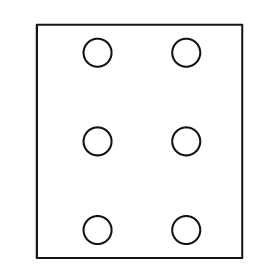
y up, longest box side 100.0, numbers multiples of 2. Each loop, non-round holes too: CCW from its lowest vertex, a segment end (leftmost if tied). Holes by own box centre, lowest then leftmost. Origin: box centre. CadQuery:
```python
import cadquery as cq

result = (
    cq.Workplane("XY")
    .moveTo(-44.0, -50.0)
    .lineTo(44.0, -50.0)
    .lineTo(44.0, 50.0)
    .lineTo(-44.0, 50.0)
    .close()
    .moveTo(-18.0, -38.0)
    .circle(6.0)
    .moveTo(20.0, -38.0)
    .circle(6.0)
    .moveTo(-18.0, 0.0)
    .circle(6.0)
    .moveTo(20.0, 0.0)
    .circle(6.0)
    .moveTo(-18.0, 38.0)
    .circle(6.0)
    .moveTo(20.0, 38.0)
    .circle(6.0)
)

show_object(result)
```